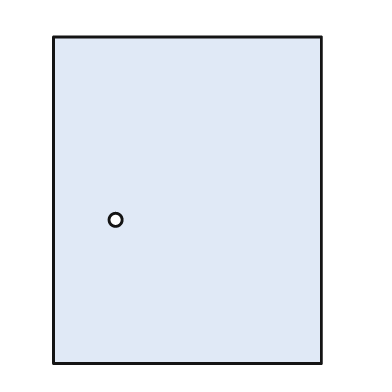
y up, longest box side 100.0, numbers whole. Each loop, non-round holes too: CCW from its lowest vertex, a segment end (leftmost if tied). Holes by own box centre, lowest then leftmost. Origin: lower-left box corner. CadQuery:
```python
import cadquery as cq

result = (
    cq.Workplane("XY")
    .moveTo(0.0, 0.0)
    .lineTo(82.0, 0.0)
    .lineTo(82.0, 100.0)
    .lineTo(0.0, 100.0)
    .close()
    .moveTo(19.0, 44.0)
    .circle(2.0)
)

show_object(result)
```